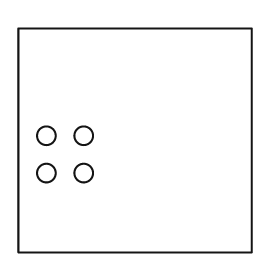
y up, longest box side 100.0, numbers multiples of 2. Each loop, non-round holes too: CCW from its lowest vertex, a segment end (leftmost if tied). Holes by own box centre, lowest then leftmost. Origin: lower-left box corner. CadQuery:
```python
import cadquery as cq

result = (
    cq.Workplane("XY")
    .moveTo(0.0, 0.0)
    .lineTo(100.0, 0.0)
    .lineTo(100.0, 96.0)
    .lineTo(0.0, 96.0)
    .close()
    .moveTo(12.0, 34.0)
    .circle(4.0)
    .moveTo(28.0, 34.0)
    .circle(4.0)
    .moveTo(12.0, 50.0)
    .circle(4.0)
    .moveTo(28.0, 50.0)
    .circle(4.0)
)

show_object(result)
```